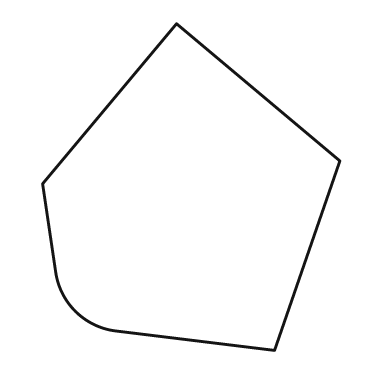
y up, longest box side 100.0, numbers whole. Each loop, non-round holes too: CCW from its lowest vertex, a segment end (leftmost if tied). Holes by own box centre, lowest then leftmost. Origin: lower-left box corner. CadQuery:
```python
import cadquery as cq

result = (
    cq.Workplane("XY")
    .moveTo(71.0, 0.0)
    .lineTo(91.0, 58.0)
    .lineTo(41.0, 100.0)
    .lineTo(0.0, 51.0)
    .lineTo(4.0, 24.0)
    .threePointArc((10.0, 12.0), (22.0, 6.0))
    .close()
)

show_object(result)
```